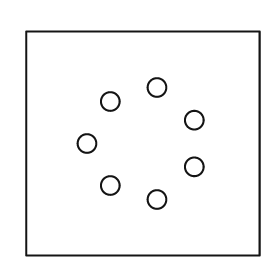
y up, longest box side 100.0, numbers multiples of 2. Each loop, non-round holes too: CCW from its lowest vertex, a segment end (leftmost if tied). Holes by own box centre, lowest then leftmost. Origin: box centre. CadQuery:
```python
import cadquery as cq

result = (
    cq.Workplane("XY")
    .moveTo(-50.0, -48.0)
    .lineTo(50.0, -48.0)
    .lineTo(50.0, 48.0)
    .lineTo(-50.0, 48.0)
    .close()
    .moveTo(6.0, -24.0)
    .circle(4.0)
    .moveTo(-14.0, -18.0)
    .circle(4.0)
    .moveTo(22.0, -10.0)
    .circle(4.0)
    .moveTo(-24.0, 0.0)
    .circle(4.0)
    .moveTo(22.0, 10.0)
    .circle(4.0)
    .moveTo(-14.0, 18.0)
    .circle(4.0)
    .moveTo(6.0, 24.0)
    .circle(4.0)
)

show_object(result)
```